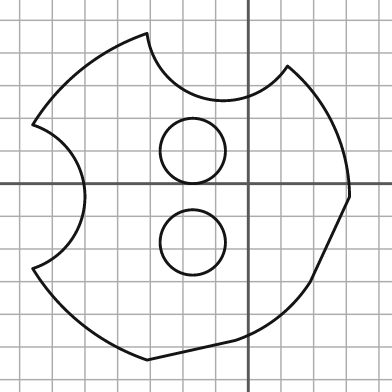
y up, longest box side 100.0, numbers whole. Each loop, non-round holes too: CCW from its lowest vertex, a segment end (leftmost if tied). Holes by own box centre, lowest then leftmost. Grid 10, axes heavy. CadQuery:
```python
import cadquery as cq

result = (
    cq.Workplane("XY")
    .moveTo(-31.0, -54.0)
    .lineTo(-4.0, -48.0)
    .threePointArc((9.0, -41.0), (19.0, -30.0))
    .lineTo(31.0, -4.0)
    .threePointArc((26.0, 18.0), (12.0, 36.0))
    .threePointArc((-13.0, 26.0), (-31.0, 46.0))
    .threePointArc((-51.0, 35.0), (-66.0, 18.0))
    .threePointArc((-50.0, -4.0), (-66.0, -26.0))
    .threePointArc((-51.0, -43.0), (-31.0, -54.0))
    .close()
    .moveTo(-17.0, -18.0)
    .circle(10.0)
    .moveTo(-17.0, 10.0)
    .circle(10.0)
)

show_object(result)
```